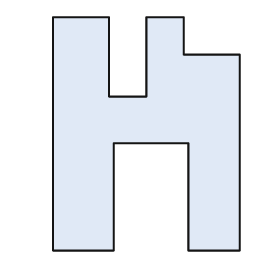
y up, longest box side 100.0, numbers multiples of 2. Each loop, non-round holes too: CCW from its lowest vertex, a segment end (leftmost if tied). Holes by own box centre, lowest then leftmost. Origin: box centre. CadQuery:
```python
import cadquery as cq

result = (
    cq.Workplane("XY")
    .moveTo(-40.0, -50.0)
    .lineTo(-14.0, -50.0)
    .lineTo(-14.0, -4.0)
    .lineTo(18.0, -4.0)
    .lineTo(18.0, -50.0)
    .lineTo(40.0, -50.0)
    .lineTo(40.0, 34.0)
    .lineTo(16.0, 34.0)
    .lineTo(16.0, 50.0)
    .lineTo(0.0, 50.0)
    .lineTo(0.0, 16.0)
    .lineTo(-16.0, 16.0)
    .lineTo(-16.0, 50.0)
    .lineTo(-40.0, 50.0)
    .close()
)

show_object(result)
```